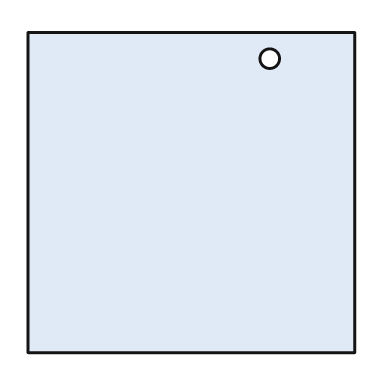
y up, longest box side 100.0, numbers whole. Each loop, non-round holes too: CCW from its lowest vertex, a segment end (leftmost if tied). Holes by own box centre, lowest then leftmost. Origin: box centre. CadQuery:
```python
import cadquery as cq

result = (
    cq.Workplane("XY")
    .moveTo(-50.0, -49.0)
    .lineTo(50.0, -49.0)
    .lineTo(50.0, 49.0)
    .lineTo(-50.0, 49.0)
    .close()
    .moveTo(24.0, 41.0)
    .circle(3.0)
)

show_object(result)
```